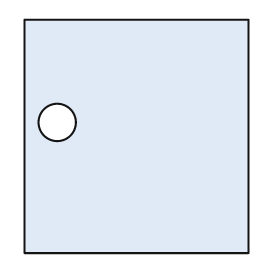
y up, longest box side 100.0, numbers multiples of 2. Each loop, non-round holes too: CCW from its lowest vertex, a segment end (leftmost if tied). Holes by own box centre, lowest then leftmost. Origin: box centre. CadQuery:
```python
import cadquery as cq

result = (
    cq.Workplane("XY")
    .moveTo(-48.0, -50.0)
    .lineTo(48.0, -50.0)
    .lineTo(48.0, 50.0)
    .lineTo(-48.0, 50.0)
    .close()
    .moveTo(-34.0, 6.0)
    .circle(8.0)
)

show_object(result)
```